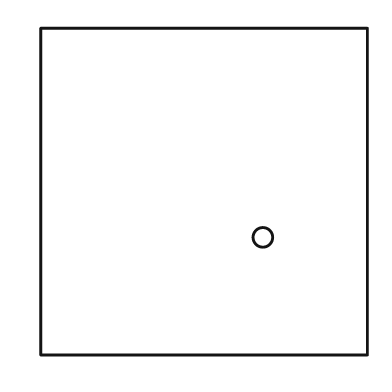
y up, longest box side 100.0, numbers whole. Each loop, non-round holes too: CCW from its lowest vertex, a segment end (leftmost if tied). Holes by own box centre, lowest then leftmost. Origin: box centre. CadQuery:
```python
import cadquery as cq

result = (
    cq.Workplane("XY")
    .moveTo(-50.0, -50.0)
    .lineTo(50.0, -50.0)
    .lineTo(50.0, 50.0)
    .lineTo(-50.0, 50.0)
    .close()
    .moveTo(18.0, -14.0)
    .circle(3.0)
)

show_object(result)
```